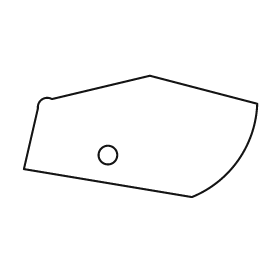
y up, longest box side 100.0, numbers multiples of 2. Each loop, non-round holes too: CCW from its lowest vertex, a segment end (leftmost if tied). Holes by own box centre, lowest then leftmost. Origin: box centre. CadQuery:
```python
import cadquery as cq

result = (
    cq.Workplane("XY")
    .moveTo(22.0, -26.0)
    .threePointArc((42.0, -10.0), (50.0, 14.0))
    .lineTo(4.0, 26.0)
    .lineTo(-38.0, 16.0)
    .threePointArc((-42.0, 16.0), (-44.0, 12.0))
    .lineTo(-50.0, -14.0)
    .close()
    .moveTo(-14.0, -8.0)
    .circle(4.0)
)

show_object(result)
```